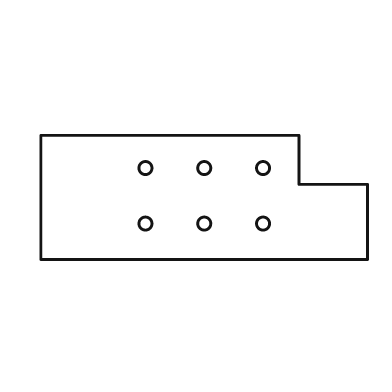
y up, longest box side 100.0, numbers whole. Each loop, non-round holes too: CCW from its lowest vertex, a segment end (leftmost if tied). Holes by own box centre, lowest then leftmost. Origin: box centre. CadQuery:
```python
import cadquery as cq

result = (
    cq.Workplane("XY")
    .moveTo(-50.0, -19.0)
    .lineTo(50.0, -19.0)
    .lineTo(50.0, 4.0)
    .lineTo(29.0, 4.0)
    .lineTo(29.0, 19.0)
    .lineTo(-50.0, 19.0)
    .close()
    .moveTo(-18.0, -8.0)
    .circle(2.0)
    .moveTo(0.0, -8.0)
    .circle(2.0)
    .moveTo(18.0, -8.0)
    .circle(2.0)
    .moveTo(-18.0, 9.0)
    .circle(2.0)
    .moveTo(0.0, 9.0)
    .circle(2.0)
    .moveTo(18.0, 9.0)
    .circle(2.0)
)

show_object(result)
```